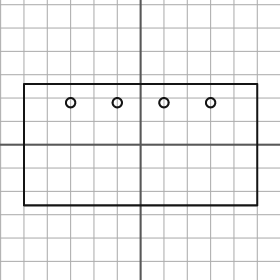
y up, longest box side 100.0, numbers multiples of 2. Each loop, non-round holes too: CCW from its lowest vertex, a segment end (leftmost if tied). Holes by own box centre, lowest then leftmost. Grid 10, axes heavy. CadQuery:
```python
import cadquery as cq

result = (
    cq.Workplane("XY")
    .moveTo(-50.0, -26.0)
    .lineTo(50.0, -26.0)
    .lineTo(50.0, 26.0)
    .lineTo(-50.0, 26.0)
    .close()
    .moveTo(-30.0, 18.0)
    .circle(2.0)
    .moveTo(-10.0, 18.0)
    .circle(2.0)
    .moveTo(10.0, 18.0)
    .circle(2.0)
    .moveTo(30.0, 18.0)
    .circle(2.0)
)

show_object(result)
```